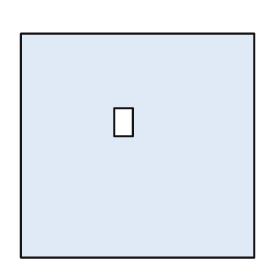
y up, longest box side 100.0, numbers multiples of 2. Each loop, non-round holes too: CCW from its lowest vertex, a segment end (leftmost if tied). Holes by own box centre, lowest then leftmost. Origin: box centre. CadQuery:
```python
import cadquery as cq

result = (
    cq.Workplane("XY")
    .moveTo(-50.0, -48.0)
    .lineTo(50.0, -48.0)
    .lineTo(50.0, 48.0)
    .lineTo(-50.0, 48.0)
    .close()
    .moveTo(-10.0, 4.0)
    .lineTo(-2.0, 4.0)
    .lineTo(-2.0, 16.0)
    .lineTo(-10.0, 16.0)
    .close()
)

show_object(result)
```